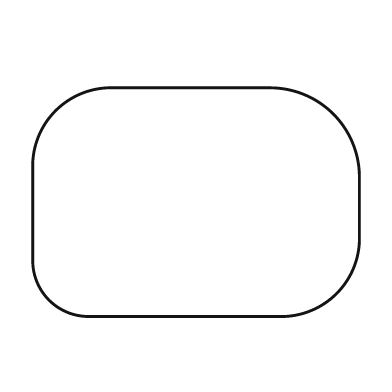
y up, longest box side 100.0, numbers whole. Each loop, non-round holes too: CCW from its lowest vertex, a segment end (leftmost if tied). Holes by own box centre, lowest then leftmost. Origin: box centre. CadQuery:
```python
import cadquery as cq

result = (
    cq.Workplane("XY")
    .moveTo(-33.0, -35.0)
    .lineTo(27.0, -35.0)
    .threePointArc((43.0, -28.0), (50.0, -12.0))
    .lineTo(50.0, 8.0)
    .threePointArc((42.0, 27.0), (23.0, 35.0))
    .lineTo(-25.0, 35.0)
    .threePointArc((-43.0, 28.0), (-50.0, 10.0))
    .lineTo(-50.0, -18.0)
    .threePointArc((-45.0, -30.0), (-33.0, -35.0))
    .close()
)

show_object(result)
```